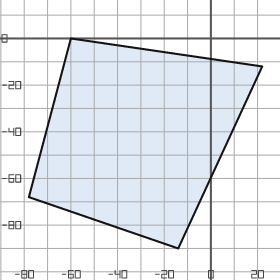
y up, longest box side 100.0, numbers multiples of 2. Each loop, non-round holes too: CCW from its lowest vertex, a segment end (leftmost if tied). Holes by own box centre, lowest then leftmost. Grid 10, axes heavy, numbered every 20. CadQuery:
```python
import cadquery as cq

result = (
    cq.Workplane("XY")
    .moveTo(-14.0, -90.0)
    .lineTo(22.0, -12.0)
    .lineTo(-60.0, 0.0)
    .lineTo(-78.0, -68.0)
    .close()
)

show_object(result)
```